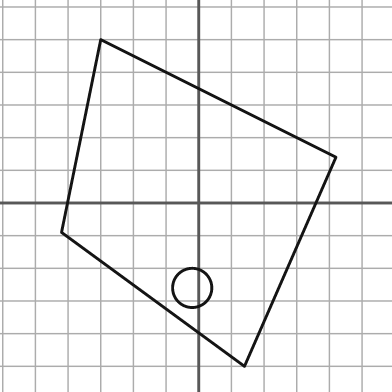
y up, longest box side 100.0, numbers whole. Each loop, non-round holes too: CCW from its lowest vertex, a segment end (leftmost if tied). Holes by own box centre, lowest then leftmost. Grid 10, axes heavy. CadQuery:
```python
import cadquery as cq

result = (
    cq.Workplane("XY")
    .moveTo(14.0, -50.0)
    .lineTo(42.0, 14.0)
    .lineTo(-30.0, 50.0)
    .lineTo(-42.0, -9.0)
    .close()
    .moveTo(-2.0, -26.0)
    .circle(6.0)
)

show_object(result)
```